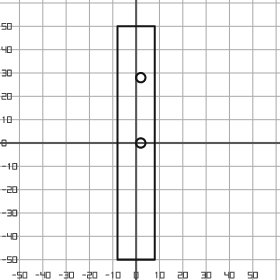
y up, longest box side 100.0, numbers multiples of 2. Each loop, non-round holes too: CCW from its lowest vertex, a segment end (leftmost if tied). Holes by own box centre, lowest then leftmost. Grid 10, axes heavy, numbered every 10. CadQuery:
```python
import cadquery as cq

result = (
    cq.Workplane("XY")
    .moveTo(-8.0, -50.0)
    .lineTo(8.0, -50.0)
    .lineTo(8.0, 50.0)
    .lineTo(-8.0, 50.0)
    .close()
    .moveTo(2.0, 0.0)
    .circle(2.0)
    .moveTo(2.0, 28.0)
    .circle(2.0)
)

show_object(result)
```